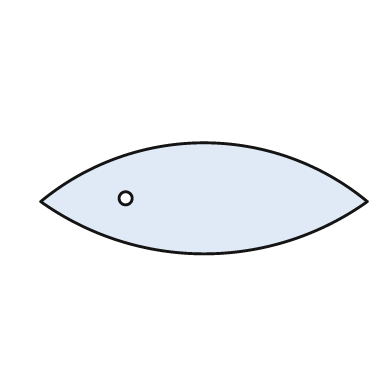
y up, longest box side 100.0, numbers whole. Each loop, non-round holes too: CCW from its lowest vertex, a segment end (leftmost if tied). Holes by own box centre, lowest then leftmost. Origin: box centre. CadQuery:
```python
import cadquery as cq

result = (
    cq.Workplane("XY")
    .moveTo(-50.0, -1.0)
    .threePointArc((0.0, -17.0), (50.0, -1.0))
    .threePointArc((0.0, 17.0), (-50.0, -1.0))
    .close()
    .moveTo(-24.0, 0.0)
    .circle(2.0)
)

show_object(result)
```